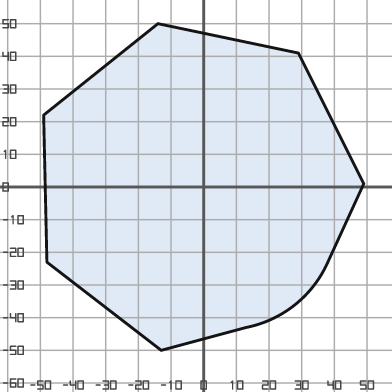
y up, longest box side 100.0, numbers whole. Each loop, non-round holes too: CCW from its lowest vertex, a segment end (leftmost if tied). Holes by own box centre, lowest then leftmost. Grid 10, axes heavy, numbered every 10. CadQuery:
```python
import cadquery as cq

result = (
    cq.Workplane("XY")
    .moveTo(-13.0, -50.0)
    .lineTo(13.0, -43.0)
    .threePointArc((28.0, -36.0), (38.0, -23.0))
    .lineTo(49.0, 1.0)
    .lineTo(29.0, 41.0)
    .lineTo(-14.0, 50.0)
    .lineTo(-49.0, 22.0)
    .lineTo(-48.0, -23.0)
    .close()
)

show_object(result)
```